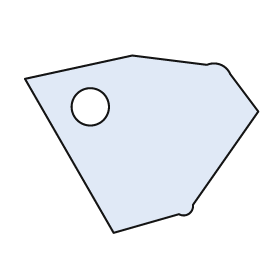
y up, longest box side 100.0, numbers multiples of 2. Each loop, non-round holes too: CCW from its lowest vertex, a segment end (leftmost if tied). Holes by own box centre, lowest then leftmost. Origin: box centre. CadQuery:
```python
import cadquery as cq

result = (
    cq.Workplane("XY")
    .moveTo(-12.0, -38.0)
    .lineTo(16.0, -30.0)
    .threePointArc((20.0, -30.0), (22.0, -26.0))
    .lineTo(50.0, 14.0)
    .lineTo(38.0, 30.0)
    .threePointArc((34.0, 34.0), (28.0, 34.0))
    .lineTo(-4.0, 38.0)
    .lineTo(-50.0, 28.0)
    .close()
    .moveTo(-22.0, 16.0)
    .circle(8.0)
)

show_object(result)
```